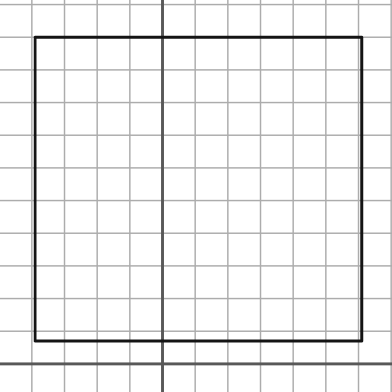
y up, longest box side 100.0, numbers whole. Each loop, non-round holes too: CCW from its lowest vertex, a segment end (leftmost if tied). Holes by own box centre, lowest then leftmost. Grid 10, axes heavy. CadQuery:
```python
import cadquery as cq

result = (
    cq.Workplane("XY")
    .moveTo(-39.0, 7.0)
    .lineTo(61.0, 7.0)
    .lineTo(61.0, 100.0)
    .lineTo(-39.0, 100.0)
    .close()
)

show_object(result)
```